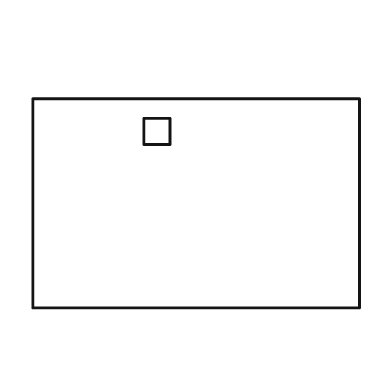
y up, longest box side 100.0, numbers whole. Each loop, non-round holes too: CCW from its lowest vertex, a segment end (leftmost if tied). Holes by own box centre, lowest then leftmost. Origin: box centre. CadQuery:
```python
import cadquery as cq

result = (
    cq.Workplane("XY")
    .moveTo(-50.0, -32.0)
    .lineTo(50.0, -32.0)
    .lineTo(50.0, 32.0)
    .lineTo(-50.0, 32.0)
    .close()
    .moveTo(-16.0, 18.0)
    .lineTo(-8.0, 18.0)
    .lineTo(-8.0, 26.0)
    .lineTo(-16.0, 26.0)
    .close()
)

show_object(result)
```